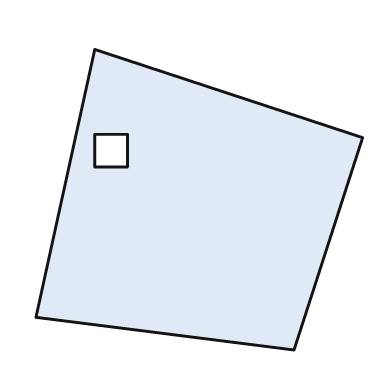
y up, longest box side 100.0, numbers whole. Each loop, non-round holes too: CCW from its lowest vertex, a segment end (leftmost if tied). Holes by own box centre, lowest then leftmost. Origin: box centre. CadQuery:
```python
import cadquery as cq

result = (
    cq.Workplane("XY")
    .moveTo(29.0, -46.0)
    .lineTo(50.0, 19.0)
    .lineTo(-32.0, 46.0)
    .lineTo(-50.0, -36.0)
    .close()
    .moveTo(-32.0, 10.0)
    .lineTo(-22.0, 10.0)
    .lineTo(-22.0, 20.0)
    .lineTo(-32.0, 20.0)
    .close()
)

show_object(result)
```